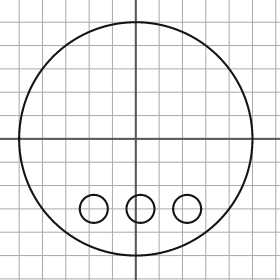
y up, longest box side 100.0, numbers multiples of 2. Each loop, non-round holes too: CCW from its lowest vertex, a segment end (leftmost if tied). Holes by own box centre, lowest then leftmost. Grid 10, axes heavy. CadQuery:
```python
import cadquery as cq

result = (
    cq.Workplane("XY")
    .moveTo(0.0, 0.0)
    .circle(50.0)
    .moveTo(-18.0, -30.0)
    .circle(6.0)
    .moveTo(2.0, -30.0)
    .circle(6.0)
    .moveTo(22.0, -30.0)
    .circle(6.0)
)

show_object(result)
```